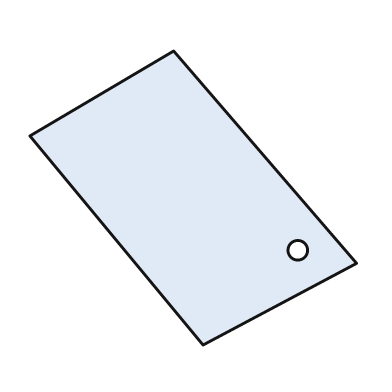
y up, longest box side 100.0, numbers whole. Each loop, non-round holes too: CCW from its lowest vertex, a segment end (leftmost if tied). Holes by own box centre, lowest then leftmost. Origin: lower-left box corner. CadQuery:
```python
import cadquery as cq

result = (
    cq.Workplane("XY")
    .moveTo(53.0, 0.0)
    .lineTo(100.0, 25.0)
    .lineTo(44.0, 90.0)
    .lineTo(0.0, 64.0)
    .close()
    .moveTo(82.0, 29.0)
    .circle(3.0)
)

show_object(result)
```